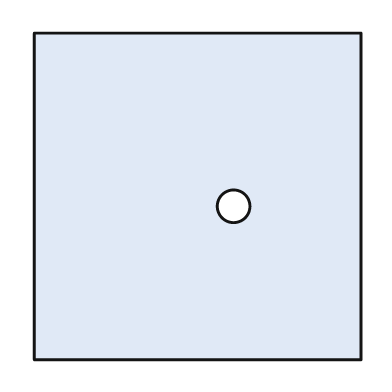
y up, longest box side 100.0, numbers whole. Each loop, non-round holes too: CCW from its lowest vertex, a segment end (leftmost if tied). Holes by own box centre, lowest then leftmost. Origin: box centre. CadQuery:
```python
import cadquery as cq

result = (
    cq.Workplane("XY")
    .moveTo(-50.0, -50.0)
    .lineTo(50.0, -50.0)
    .lineTo(50.0, 50.0)
    .lineTo(-50.0, 50.0)
    .close()
    .moveTo(11.0, -3.0)
    .circle(5.0)
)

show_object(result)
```